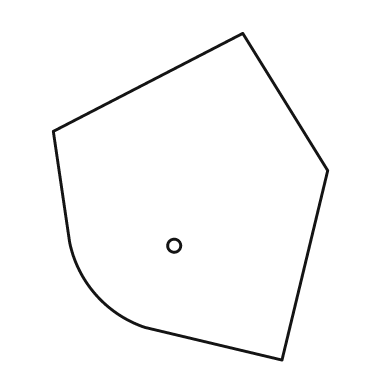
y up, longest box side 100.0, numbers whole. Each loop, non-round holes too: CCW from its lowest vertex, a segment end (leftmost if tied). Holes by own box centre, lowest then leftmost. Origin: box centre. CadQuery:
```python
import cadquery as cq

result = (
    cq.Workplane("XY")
    .moveTo(28.0, -50.0)
    .lineTo(42.0, 8.0)
    .lineTo(16.0, 50.0)
    .lineTo(-42.0, 20.0)
    .lineTo(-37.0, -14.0)
    .threePointArc((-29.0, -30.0), (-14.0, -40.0))
    .close()
    .moveTo(-5.0, -15.0)
    .circle(2.0)
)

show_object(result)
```